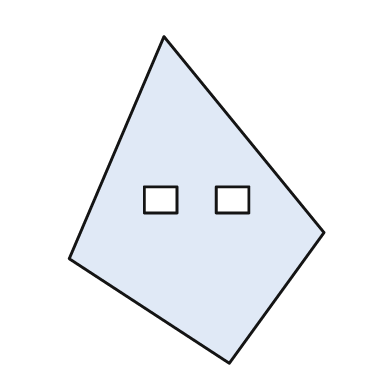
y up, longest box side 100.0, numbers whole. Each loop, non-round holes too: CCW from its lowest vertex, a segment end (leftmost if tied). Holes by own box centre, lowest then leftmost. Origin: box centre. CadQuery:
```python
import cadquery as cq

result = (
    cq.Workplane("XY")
    .moveTo(10.0, -50.0)
    .lineTo(39.0, -10.0)
    .lineTo(-10.0, 50.0)
    .lineTo(-39.0, -18.0)
    .close()
    .moveTo(-16.0, -4.0)
    .lineTo(-6.0, -4.0)
    .lineTo(-6.0, 4.0)
    .lineTo(-16.0, 4.0)
    .close()
    .moveTo(6.0, -4.0)
    .lineTo(16.0, -4.0)
    .lineTo(16.0, 4.0)
    .lineTo(6.0, 4.0)
    .close()
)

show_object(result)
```